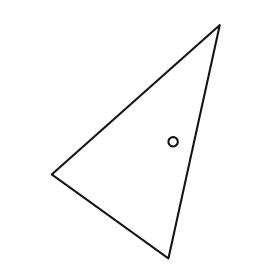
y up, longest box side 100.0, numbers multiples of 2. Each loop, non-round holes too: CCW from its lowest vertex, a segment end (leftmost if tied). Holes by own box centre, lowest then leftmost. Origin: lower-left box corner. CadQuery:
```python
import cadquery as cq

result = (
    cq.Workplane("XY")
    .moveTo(50.0, 0.0)
    .lineTo(72.0, 100.0)
    .lineTo(0.0, 36.0)
    .close()
    .moveTo(52.0, 50.0)
    .circle(2.0)
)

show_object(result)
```